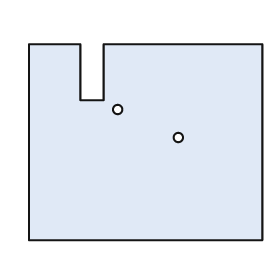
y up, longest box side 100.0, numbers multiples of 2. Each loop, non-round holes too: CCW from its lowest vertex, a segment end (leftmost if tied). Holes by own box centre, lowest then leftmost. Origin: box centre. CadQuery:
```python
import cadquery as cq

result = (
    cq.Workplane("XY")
    .moveTo(-50.0, -42.0)
    .lineTo(50.0, -42.0)
    .lineTo(50.0, 42.0)
    .lineTo(-18.0, 42.0)
    .lineTo(-18.0, 18.0)
    .lineTo(-28.0, 18.0)
    .lineTo(-28.0, 42.0)
    .lineTo(-50.0, 42.0)
    .close()
    .moveTo(14.0, 2.0)
    .circle(2.0)
    .moveTo(-12.0, 14.0)
    .circle(2.0)
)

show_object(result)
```